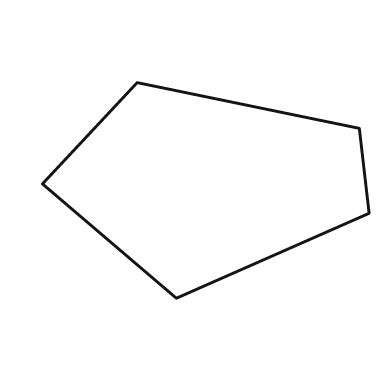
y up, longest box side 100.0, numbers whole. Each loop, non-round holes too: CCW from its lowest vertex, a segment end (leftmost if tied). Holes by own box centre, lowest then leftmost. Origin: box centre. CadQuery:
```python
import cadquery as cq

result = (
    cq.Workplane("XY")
    .moveTo(-9.0, -33.0)
    .lineTo(50.0, -7.0)
    .lineTo(47.0, 19.0)
    .lineTo(-21.0, 33.0)
    .lineTo(-50.0, 2.0)
    .close()
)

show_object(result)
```